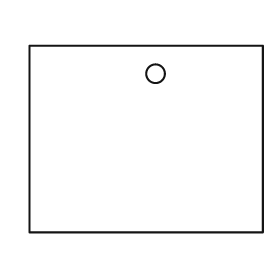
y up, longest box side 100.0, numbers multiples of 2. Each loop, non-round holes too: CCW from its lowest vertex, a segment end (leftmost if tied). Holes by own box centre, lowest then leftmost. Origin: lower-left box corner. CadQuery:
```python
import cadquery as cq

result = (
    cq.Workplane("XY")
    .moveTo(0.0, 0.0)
    .lineTo(100.0, 0.0)
    .lineTo(100.0, 80.0)
    .lineTo(0.0, 80.0)
    .close()
    .moveTo(54.0, 68.0)
    .circle(4.0)
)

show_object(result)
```